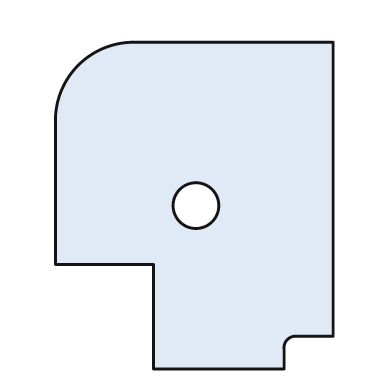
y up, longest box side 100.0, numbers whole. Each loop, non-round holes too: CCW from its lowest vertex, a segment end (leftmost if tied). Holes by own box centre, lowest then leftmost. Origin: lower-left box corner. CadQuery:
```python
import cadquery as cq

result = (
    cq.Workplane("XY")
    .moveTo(30.0, 0.0)
    .lineTo(70.0, 0.0)
    .lineTo(70.0, 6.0)
    .threePointArc((71.0, 9.0), (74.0, 10.0))
    .lineTo(85.0, 10.0)
    .lineTo(85.0, 100.0)
    .lineTo(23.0, 100.0)
    .threePointArc((7.0, 93.0), (0.0, 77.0))
    .lineTo(0.0, 32.0)
    .lineTo(30.0, 32.0)
    .close()
    .moveTo(43.0, 50.0)
    .circle(7.0)
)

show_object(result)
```